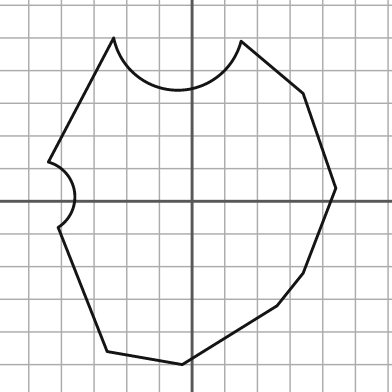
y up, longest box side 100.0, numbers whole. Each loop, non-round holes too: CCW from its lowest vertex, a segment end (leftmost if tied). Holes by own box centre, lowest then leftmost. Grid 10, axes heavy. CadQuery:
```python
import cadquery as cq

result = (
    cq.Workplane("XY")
    .moveTo(-3.0, -50.0)
    .lineTo(26.0, -32.0)
    .lineTo(34.0, -22.0)
    .lineTo(44.0, 4.0)
    .lineTo(34.0, 33.0)
    .lineTo(15.0, 49.0)
    .threePointArc((-5.0, 34.0), (-24.0, 50.0))
    .lineTo(-44.0, 12.0)
    .threePointArc((-36.0, 3.0), (-41.0, -8.0))
    .lineTo(-26.0, -46.0)
    .close()
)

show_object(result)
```